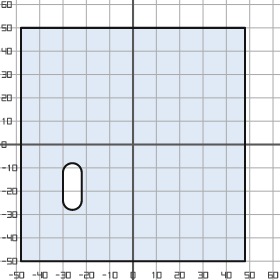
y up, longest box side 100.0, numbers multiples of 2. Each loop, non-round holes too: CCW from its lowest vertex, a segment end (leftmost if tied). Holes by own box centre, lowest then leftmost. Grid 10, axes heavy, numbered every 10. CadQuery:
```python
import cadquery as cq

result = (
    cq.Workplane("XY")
    .moveTo(-48.0, -50.0)
    .lineTo(48.0, -50.0)
    .lineTo(48.0, 50.0)
    .lineTo(-48.0, 50.0)
    .close()
    .moveTo(-30.0, -24.0)
    .threePointArc((-26.0, -28.0), (-22.0, -24.0))
    .lineTo(-22.0, -12.0)
    .threePointArc((-26.0, -8.0), (-30.0, -12.0))
    .close()
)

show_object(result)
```